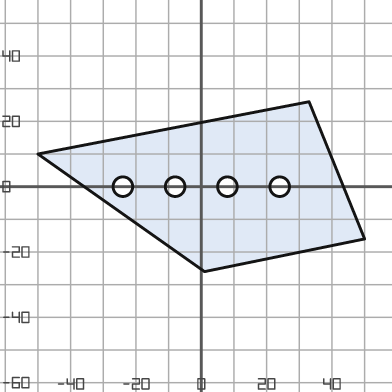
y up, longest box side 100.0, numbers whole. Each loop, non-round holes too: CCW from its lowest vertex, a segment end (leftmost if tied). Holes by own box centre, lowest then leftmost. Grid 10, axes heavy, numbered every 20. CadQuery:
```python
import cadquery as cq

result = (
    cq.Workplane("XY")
    .moveTo(1.0, -26.0)
    .lineTo(50.0, -16.0)
    .lineTo(33.0, 26.0)
    .lineTo(-50.0, 10.0)
    .close()
    .moveTo(-24.0, 0.0)
    .circle(3.0)
    .moveTo(-8.0, 0.0)
    .circle(3.0)
    .moveTo(8.0, 0.0)
    .circle(3.0)
    .moveTo(24.0, 0.0)
    .circle(3.0)
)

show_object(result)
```